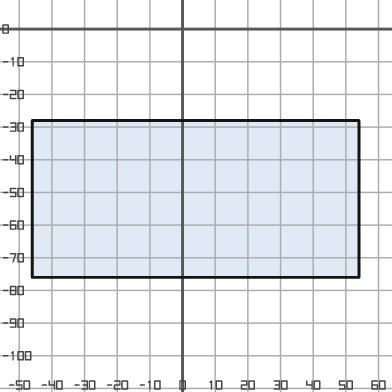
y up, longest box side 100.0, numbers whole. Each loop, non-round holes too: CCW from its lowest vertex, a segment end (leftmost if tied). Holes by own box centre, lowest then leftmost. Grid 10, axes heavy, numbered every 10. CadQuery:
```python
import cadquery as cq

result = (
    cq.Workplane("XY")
    .moveTo(-46.0, -76.0)
    .lineTo(54.0, -76.0)
    .lineTo(54.0, -28.0)
    .lineTo(-46.0, -28.0)
    .close()
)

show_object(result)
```